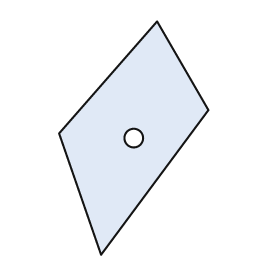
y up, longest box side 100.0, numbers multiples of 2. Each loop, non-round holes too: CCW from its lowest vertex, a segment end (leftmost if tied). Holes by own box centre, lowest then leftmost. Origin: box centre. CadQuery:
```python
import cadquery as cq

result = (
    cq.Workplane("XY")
    .moveTo(-14.0, -50.0)
    .lineTo(32.0, 12.0)
    .lineTo(10.0, 50.0)
    .lineTo(-32.0, 2.0)
    .close()
    .moveTo(0.0, 0.0)
    .circle(4.0)
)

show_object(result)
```